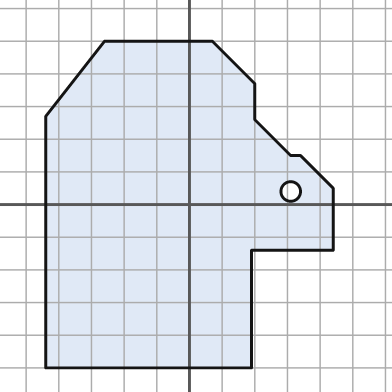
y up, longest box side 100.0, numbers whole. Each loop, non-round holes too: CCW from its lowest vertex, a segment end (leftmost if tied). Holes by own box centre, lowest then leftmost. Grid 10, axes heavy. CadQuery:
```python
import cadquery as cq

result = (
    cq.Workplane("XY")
    .moveTo(-44.0, -50.0)
    .lineTo(19.0, -50.0)
    .lineTo(19.0, -14.0)
    .lineTo(44.0, -14.0)
    .lineTo(44.0, 5.0)
    .lineTo(34.0, 15.0)
    .lineTo(31.0, 15.0)
    .lineTo(20.0, 26.0)
    .lineTo(20.0, 37.0)
    .lineTo(7.0, 50.0)
    .lineTo(-26.0, 50.0)
    .lineTo(-44.0, 27.0)
    .close()
    .moveTo(31.0, 4.0)
    .circle(3.0)
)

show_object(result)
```